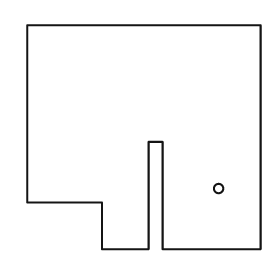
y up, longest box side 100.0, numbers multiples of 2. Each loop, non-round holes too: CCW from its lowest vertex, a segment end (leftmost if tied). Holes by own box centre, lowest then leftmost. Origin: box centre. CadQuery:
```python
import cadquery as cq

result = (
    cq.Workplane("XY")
    .moveTo(-18.0, -48.0)
    .lineTo(2.0, -48.0)
    .lineTo(2.0, -2.0)
    .lineTo(8.0, -2.0)
    .lineTo(8.0, -48.0)
    .lineTo(50.0, -48.0)
    .lineTo(50.0, 48.0)
    .lineTo(-50.0, 48.0)
    .lineTo(-50.0, -28.0)
    .lineTo(-18.0, -28.0)
    .close()
    .moveTo(32.0, -22.0)
    .circle(2.0)
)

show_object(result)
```